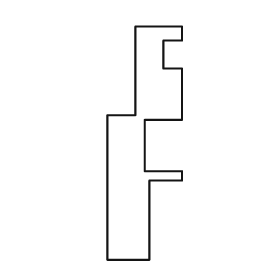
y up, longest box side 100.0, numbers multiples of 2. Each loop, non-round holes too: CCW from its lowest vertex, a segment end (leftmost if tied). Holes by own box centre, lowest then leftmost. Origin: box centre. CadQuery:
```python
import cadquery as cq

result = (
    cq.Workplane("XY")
    .moveTo(-16.0, -50.0)
    .lineTo(2.0, -50.0)
    .lineTo(2.0, -16.0)
    .lineTo(16.0, -16.0)
    .lineTo(16.0, -12.0)
    .lineTo(0.0, -12.0)
    .lineTo(0.0, 10.0)
    .lineTo(16.0, 10.0)
    .lineTo(16.0, 32.0)
    .lineTo(8.0, 32.0)
    .lineTo(8.0, 44.0)
    .lineTo(16.0, 44.0)
    .lineTo(16.0, 50.0)
    .lineTo(-4.0, 50.0)
    .lineTo(-4.0, 12.0)
    .lineTo(-16.0, 12.0)
    .close()
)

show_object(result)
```